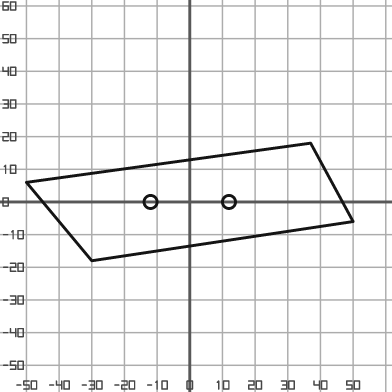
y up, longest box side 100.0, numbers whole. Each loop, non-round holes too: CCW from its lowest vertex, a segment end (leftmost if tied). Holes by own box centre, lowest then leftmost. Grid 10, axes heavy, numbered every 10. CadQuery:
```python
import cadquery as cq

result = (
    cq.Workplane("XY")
    .moveTo(-30.0, -18.0)
    .lineTo(50.0, -6.0)
    .lineTo(37.0, 18.0)
    .lineTo(-50.0, 6.0)
    .close()
    .moveTo(-12.0, 0.0)
    .circle(2.0)
    .moveTo(12.0, 0.0)
    .circle(2.0)
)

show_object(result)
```